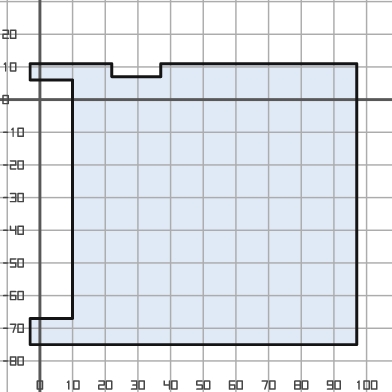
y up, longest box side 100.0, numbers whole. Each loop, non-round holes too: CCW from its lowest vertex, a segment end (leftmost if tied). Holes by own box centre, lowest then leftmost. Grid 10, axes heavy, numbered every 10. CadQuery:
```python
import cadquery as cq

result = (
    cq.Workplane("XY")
    .moveTo(-3.0, -75.0)
    .lineTo(97.0, -75.0)
    .lineTo(97.0, 11.0)
    .lineTo(37.0, 11.0)
    .lineTo(37.0, 7.0)
    .lineTo(22.0, 7.0)
    .lineTo(22.0, 11.0)
    .lineTo(-3.0, 11.0)
    .lineTo(-3.0, 6.0)
    .lineTo(10.0, 6.0)
    .lineTo(10.0, -67.0)
    .lineTo(-3.0, -67.0)
    .close()
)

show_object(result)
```